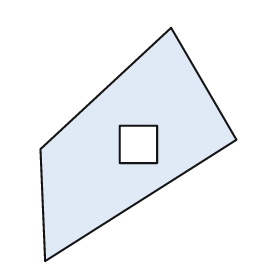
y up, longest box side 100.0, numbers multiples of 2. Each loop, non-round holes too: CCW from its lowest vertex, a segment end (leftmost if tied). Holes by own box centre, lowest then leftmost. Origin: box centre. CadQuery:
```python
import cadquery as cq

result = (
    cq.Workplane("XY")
    .moveTo(-40.0, -50.0)
    .lineTo(42.0, 2.0)
    .lineTo(14.0, 50.0)
    .lineTo(-42.0, -2.0)
    .close()
    .moveTo(-8.0, -8.0)
    .lineTo(8.0, -8.0)
    .lineTo(8.0, 8.0)
    .lineTo(-8.0, 8.0)
    .close()
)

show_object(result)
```